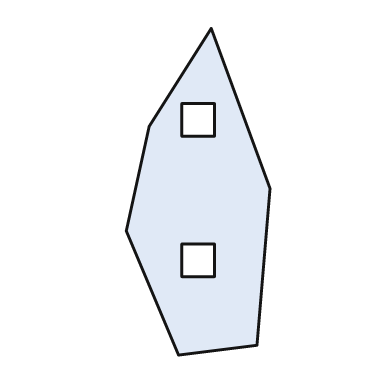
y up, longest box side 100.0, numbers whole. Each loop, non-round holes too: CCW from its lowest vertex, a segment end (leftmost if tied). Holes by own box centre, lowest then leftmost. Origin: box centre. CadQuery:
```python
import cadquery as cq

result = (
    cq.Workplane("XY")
    .moveTo(-6.0, -50.0)
    .lineTo(18.0, -47.0)
    .lineTo(22.0, 1.0)
    .lineTo(4.0, 50.0)
    .lineTo(-15.0, 20.0)
    .lineTo(-22.0, -12.0)
    .close()
    .moveTo(-5.0, -26.0)
    .lineTo(5.0, -26.0)
    .lineTo(5.0, -16.0)
    .lineTo(-5.0, -16.0)
    .close()
    .moveTo(-5.0, 17.0)
    .lineTo(5.0, 17.0)
    .lineTo(5.0, 27.0)
    .lineTo(-5.0, 27.0)
    .close()
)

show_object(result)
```